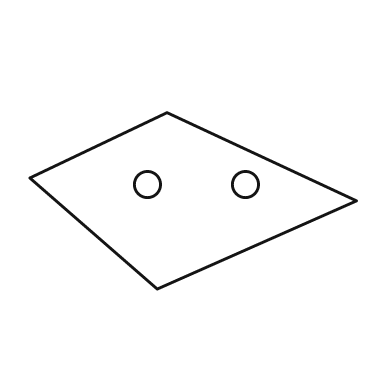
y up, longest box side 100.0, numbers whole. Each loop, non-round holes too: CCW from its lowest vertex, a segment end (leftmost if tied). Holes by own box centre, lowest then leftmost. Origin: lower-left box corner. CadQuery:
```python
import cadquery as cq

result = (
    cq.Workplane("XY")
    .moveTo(39.0, 0.0)
    .lineTo(100.0, 27.0)
    .lineTo(42.0, 54.0)
    .lineTo(0.0, 34.0)
    .close()
    .moveTo(36.0, 32.0)
    .circle(4.0)
    .moveTo(66.0, 32.0)
    .circle(4.0)
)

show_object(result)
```